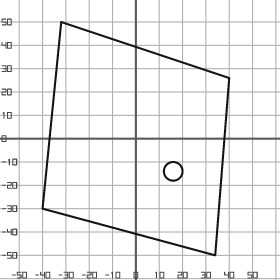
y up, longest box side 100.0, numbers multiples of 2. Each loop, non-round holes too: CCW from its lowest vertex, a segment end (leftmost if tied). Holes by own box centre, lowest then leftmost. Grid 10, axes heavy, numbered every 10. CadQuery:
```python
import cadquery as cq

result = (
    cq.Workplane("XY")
    .moveTo(34.0, -50.0)
    .lineTo(40.0, 26.0)
    .lineTo(-32.0, 50.0)
    .lineTo(-40.0, -30.0)
    .close()
    .moveTo(16.0, -14.0)
    .circle(4.0)
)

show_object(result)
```